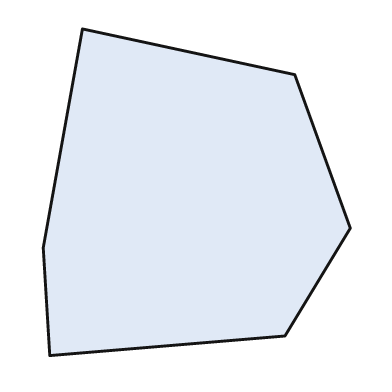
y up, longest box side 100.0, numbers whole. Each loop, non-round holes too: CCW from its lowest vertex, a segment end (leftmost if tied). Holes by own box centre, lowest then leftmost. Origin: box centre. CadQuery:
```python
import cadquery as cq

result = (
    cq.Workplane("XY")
    .moveTo(-45.0, -50.0)
    .lineTo(27.0, -44.0)
    .lineTo(47.0, -11.0)
    .lineTo(30.0, 36.0)
    .lineTo(-35.0, 50.0)
    .lineTo(-47.0, -17.0)
    .close()
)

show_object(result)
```